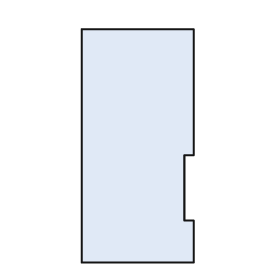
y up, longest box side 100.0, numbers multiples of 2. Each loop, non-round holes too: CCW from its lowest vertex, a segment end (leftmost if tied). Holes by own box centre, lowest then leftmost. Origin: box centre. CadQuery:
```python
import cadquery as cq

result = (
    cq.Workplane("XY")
    .moveTo(-24.0, -50.0)
    .lineTo(24.0, -50.0)
    .lineTo(24.0, -32.0)
    .lineTo(20.0, -32.0)
    .lineTo(20.0, -4.0)
    .lineTo(24.0, -4.0)
    .lineTo(24.0, 50.0)
    .lineTo(-24.0, 50.0)
    .close()
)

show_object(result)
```